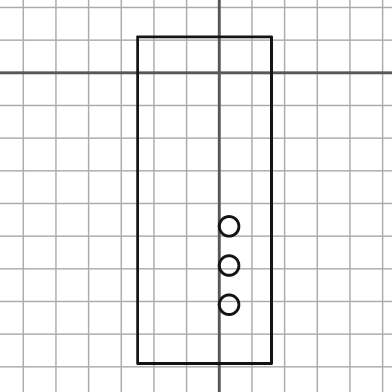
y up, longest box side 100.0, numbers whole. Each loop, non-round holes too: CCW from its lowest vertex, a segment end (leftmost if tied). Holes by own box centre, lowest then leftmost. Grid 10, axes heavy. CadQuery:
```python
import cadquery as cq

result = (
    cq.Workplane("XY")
    .moveTo(-25.0, -89.0)
    .lineTo(16.0, -89.0)
    .lineTo(16.0, 11.0)
    .lineTo(-25.0, 11.0)
    .close()
    .moveTo(3.0, -71.0)
    .circle(3.0)
    .moveTo(3.0, -59.0)
    .circle(3.0)
    .moveTo(3.0, -47.0)
    .circle(3.0)
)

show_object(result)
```